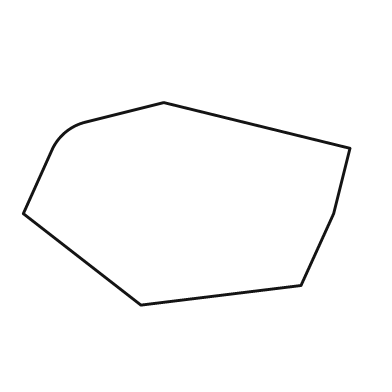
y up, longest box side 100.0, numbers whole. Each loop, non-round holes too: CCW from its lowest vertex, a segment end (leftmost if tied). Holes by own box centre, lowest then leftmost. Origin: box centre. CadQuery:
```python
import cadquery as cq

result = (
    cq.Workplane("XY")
    .moveTo(-14.0, -31.0)
    .lineTo(35.0, -25.0)
    .lineTo(45.0, -3.0)
    .lineTo(50.0, 17.0)
    .lineTo(-7.0, 31.0)
    .lineTo(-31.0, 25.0)
    .threePointArc((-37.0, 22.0), (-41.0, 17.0))
    .lineTo(-50.0, -3.0)
    .close()
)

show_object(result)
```